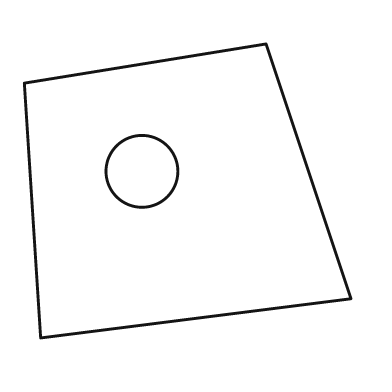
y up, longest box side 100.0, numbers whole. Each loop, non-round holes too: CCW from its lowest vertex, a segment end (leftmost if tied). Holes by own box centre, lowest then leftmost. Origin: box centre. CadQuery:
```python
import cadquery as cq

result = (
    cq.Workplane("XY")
    .moveTo(-45.0, -45.0)
    .lineTo(50.0, -33.0)
    .lineTo(24.0, 45.0)
    .lineTo(-50.0, 33.0)
    .close()
    .moveTo(-14.0, 6.0)
    .circle(11.0)
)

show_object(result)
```